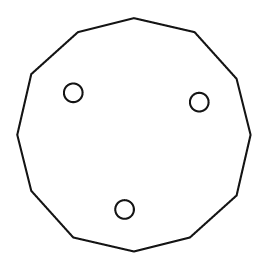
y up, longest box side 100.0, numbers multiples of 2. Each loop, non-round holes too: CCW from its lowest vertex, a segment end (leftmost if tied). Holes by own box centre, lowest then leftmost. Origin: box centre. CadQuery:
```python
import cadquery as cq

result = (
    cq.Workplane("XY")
    .moveTo(0.0, -50.0)
    .lineTo(24.0, -44.0)
    .lineTo(44.0, -26.0)
    .lineTo(50.0, 0.0)
    .lineTo(44.0, 24.0)
    .lineTo(26.0, 44.0)
    .lineTo(0.0, 50.0)
    .lineTo(-24.0, 44.0)
    .lineTo(-44.0, 26.0)
    .lineTo(-50.0, 0.0)
    .lineTo(-44.0, -24.0)
    .lineTo(-26.0, -44.0)
    .close()
    .moveTo(-4.0, -32.0)
    .circle(4.0)
    .moveTo(28.0, 14.0)
    .circle(4.0)
    .moveTo(-26.0, 18.0)
    .circle(4.0)
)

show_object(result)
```